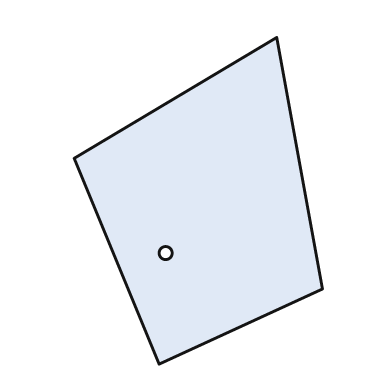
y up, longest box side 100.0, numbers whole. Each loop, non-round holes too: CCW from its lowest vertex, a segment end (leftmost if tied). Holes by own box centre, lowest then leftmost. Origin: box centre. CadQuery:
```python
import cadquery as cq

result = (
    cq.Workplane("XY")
    .moveTo(-12.0, -50.0)
    .lineTo(38.0, -27.0)
    .lineTo(24.0, 50.0)
    .lineTo(-38.0, 13.0)
    .close()
    .moveTo(-10.0, -16.0)
    .circle(2.0)
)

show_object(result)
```